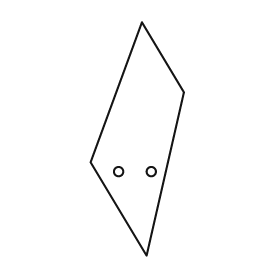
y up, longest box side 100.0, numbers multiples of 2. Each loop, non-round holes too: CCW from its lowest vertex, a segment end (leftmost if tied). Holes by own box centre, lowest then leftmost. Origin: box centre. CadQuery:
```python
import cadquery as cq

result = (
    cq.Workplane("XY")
    .moveTo(4.0, -50.0)
    .lineTo(20.0, 20.0)
    .lineTo(2.0, 50.0)
    .lineTo(-20.0, -10.0)
    .close()
    .moveTo(-8.0, -14.0)
    .circle(2.0)
    .moveTo(6.0, -14.0)
    .circle(2.0)
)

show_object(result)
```